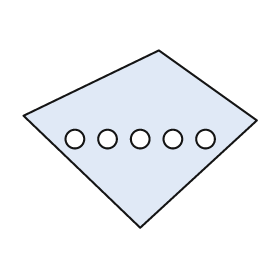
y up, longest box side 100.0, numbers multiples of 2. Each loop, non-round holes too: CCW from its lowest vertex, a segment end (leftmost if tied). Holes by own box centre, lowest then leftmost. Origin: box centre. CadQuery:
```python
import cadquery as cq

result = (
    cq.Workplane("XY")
    .moveTo(0.0, -38.0)
    .lineTo(50.0, 8.0)
    .lineTo(8.0, 38.0)
    .lineTo(-50.0, 10.0)
    .close()
    .moveTo(-28.0, 0.0)
    .circle(4.0)
    .moveTo(-14.0, 0.0)
    .circle(4.0)
    .moveTo(0.0, 0.0)
    .circle(4.0)
    .moveTo(14.0, 0.0)
    .circle(4.0)
    .moveTo(28.0, 0.0)
    .circle(4.0)
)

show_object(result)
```